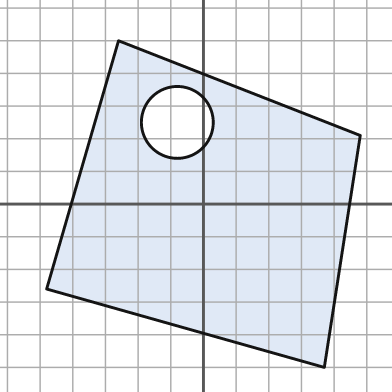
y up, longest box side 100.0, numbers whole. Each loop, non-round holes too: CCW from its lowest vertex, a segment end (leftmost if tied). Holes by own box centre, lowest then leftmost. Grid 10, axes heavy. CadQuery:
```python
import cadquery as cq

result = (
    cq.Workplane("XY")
    .moveTo(37.0, -50.0)
    .lineTo(48.0, 21.0)
    .lineTo(-26.0, 50.0)
    .lineTo(-48.0, -26.0)
    .close()
    .moveTo(-8.0, 25.0)
    .circle(11.0)
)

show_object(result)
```